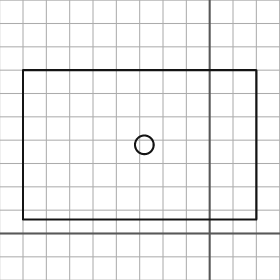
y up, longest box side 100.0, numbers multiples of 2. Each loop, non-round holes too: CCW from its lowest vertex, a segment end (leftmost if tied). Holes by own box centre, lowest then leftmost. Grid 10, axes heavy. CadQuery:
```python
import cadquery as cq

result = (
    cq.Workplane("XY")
    .moveTo(-80.0, 6.0)
    .lineTo(20.0, 6.0)
    .lineTo(20.0, 70.0)
    .lineTo(-80.0, 70.0)
    .close()
    .moveTo(-28.0, 38.0)
    .circle(4.0)
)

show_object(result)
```